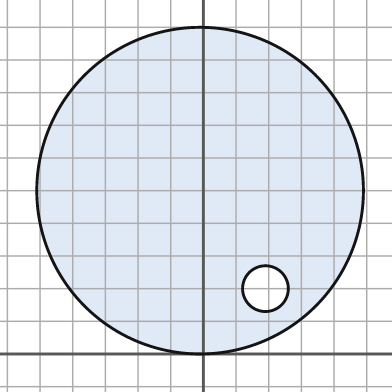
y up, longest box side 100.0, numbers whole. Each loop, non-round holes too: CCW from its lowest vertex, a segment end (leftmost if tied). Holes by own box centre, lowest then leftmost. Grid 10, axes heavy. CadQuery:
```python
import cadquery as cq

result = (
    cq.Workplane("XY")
    .moveTo(-1.0, 50.0)
    .circle(50.0)
    .moveTo(19.0, 20.0)
    .circle(7.0)
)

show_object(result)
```